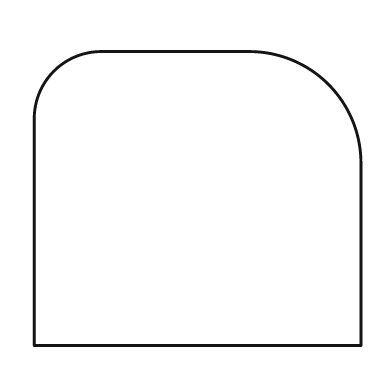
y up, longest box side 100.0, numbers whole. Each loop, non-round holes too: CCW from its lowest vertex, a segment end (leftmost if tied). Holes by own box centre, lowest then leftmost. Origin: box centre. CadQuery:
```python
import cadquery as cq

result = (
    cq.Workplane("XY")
    .moveTo(-50.0, -45.0)
    .lineTo(50.0, -45.0)
    .lineTo(50.0, 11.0)
    .threePointArc((40.0, 35.0), (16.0, 45.0))
    .lineTo(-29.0, 45.0)
    .threePointArc((-44.0, 39.0), (-50.0, 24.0))
    .close()
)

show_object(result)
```